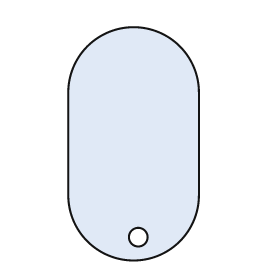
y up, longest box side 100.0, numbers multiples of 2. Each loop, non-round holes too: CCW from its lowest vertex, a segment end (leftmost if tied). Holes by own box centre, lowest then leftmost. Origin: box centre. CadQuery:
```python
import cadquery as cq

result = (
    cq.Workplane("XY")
    .moveTo(-28.0, -22.0)
    .threePointArc((0.0, -50.0), (28.0, -22.0))
    .lineTo(28.0, 22.0)
    .threePointArc((0.0, 50.0), (-28.0, 22.0))
    .close()
    .moveTo(2.0, -40.0)
    .circle(4.0)
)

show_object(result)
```